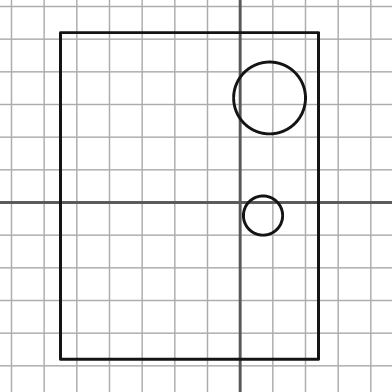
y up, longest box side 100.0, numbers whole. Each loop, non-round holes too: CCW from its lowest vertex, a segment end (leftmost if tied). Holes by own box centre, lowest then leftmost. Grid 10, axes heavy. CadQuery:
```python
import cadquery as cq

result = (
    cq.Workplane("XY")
    .moveTo(-55.0, -48.0)
    .lineTo(24.0, -48.0)
    .lineTo(24.0, 52.0)
    .lineTo(-55.0, 52.0)
    .close()
    .moveTo(7.0, -4.0)
    .circle(6.0)
    .moveTo(9.0, 32.0)
    .circle(11.0)
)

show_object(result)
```